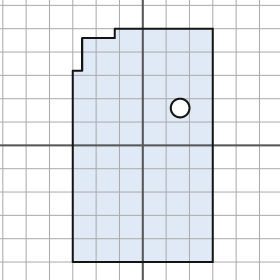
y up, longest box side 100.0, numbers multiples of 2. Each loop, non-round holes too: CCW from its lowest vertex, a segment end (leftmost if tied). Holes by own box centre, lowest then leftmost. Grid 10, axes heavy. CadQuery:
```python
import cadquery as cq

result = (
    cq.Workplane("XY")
    .moveTo(-30.0, -50.0)
    .lineTo(30.0, -50.0)
    .lineTo(30.0, 50.0)
    .lineTo(-12.0, 50.0)
    .lineTo(-12.0, 46.0)
    .lineTo(-26.0, 46.0)
    .lineTo(-26.0, 32.0)
    .lineTo(-30.0, 32.0)
    .close()
    .moveTo(16.0, 16.0)
    .circle(4.0)
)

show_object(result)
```